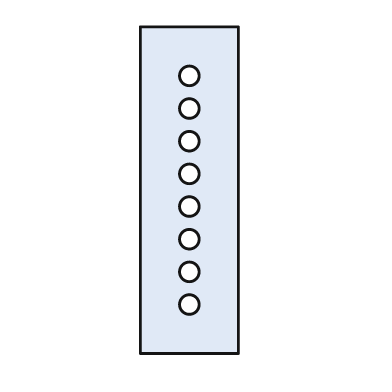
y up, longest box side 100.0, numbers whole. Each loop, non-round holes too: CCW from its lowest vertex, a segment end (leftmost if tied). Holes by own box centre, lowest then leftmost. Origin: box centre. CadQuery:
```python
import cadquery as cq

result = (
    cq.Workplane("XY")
    .moveTo(-15.0, -50.0)
    .lineTo(15.0, -50.0)
    .lineTo(15.0, 50.0)
    .lineTo(-15.0, 50.0)
    .close()
    .moveTo(0.0, -35.0)
    .circle(3.0)
    .moveTo(0.0, -25.0)
    .circle(3.0)
    .moveTo(0.0, -15.0)
    .circle(3.0)
    .moveTo(0.0, -5.0)
    .circle(3.0)
    .moveTo(0.0, 5.0)
    .circle(3.0)
    .moveTo(0.0, 15.0)
    .circle(3.0)
    .moveTo(0.0, 25.0)
    .circle(3.0)
    .moveTo(0.0, 35.0)
    .circle(3.0)
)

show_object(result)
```